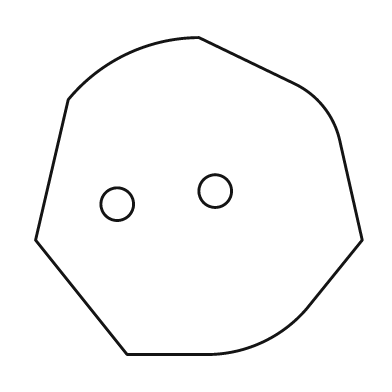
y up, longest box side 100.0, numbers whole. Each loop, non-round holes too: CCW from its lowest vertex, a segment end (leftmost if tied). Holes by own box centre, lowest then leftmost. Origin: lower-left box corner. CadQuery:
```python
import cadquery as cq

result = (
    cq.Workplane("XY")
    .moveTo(28.0, 0.0)
    .lineTo(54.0, 0.0)
    .threePointArc((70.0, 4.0), (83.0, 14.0))
    .lineTo(100.0, 35.0)
    .lineTo(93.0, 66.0)
    .threePointArc((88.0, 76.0), (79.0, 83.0))
    .lineTo(50.0, 97.0)
    .threePointArc((28.0, 92.0), (10.0, 78.0))
    .lineTo(0.0, 35.0)
    .close()
    .moveTo(25.0, 46.0)
    .circle(5.0)
    .moveTo(55.0, 50.0)
    .circle(5.0)
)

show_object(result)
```